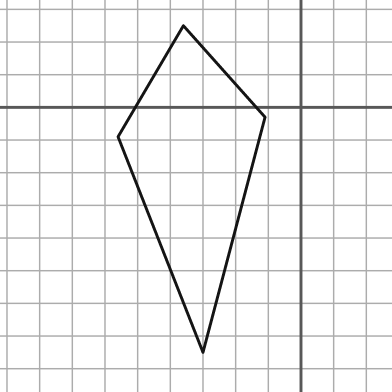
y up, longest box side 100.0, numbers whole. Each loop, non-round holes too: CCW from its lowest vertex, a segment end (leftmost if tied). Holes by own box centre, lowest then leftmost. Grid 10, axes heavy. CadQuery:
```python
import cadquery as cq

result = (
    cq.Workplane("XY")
    .moveTo(-30.0, -75.0)
    .lineTo(-11.0, -3.0)
    .lineTo(-36.0, 25.0)
    .lineTo(-56.0, -9.0)
    .close()
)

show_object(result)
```